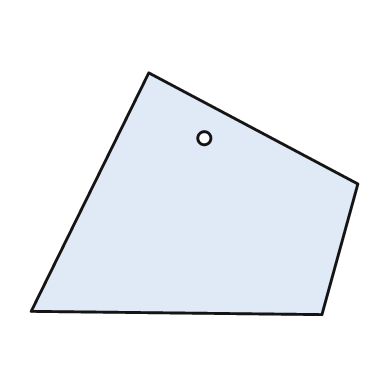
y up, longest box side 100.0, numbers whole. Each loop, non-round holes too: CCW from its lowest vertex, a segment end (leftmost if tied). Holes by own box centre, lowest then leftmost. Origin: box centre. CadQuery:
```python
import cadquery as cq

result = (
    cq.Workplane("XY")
    .moveTo(39.0, -37.0)
    .lineTo(50.0, 3.0)
    .lineTo(-14.0, 37.0)
    .lineTo(-50.0, -36.0)
    .close()
    .moveTo(3.0, 17.0)
    .circle(2.0)
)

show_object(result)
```